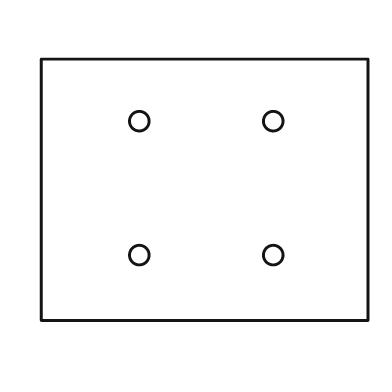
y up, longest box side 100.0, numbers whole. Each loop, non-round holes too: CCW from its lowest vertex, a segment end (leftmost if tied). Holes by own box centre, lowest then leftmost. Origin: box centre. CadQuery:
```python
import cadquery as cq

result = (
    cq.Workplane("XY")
    .moveTo(-50.0, -40.0)
    .lineTo(50.0, -40.0)
    .lineTo(50.0, 40.0)
    .lineTo(-50.0, 40.0)
    .close()
    .moveTo(-20.0, -20.0)
    .circle(3.0)
    .moveTo(21.0, -20.0)
    .circle(3.0)
    .moveTo(-20.0, 21.0)
    .circle(3.0)
    .moveTo(21.0, 21.0)
    .circle(3.0)
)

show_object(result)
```